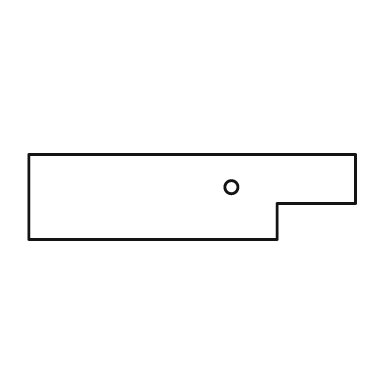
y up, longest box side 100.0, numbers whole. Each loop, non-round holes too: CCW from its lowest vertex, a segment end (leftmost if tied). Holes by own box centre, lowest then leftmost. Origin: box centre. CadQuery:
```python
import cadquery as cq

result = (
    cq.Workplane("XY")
    .moveTo(-50.0, -13.0)
    .lineTo(26.0, -13.0)
    .lineTo(26.0, -2.0)
    .lineTo(50.0, -2.0)
    .lineTo(50.0, 13.0)
    .lineTo(-50.0, 13.0)
    .close()
    .moveTo(12.0, 3.0)
    .circle(2.0)
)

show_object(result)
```